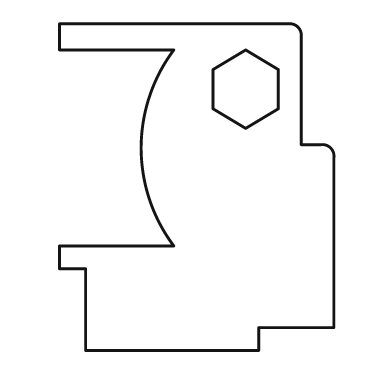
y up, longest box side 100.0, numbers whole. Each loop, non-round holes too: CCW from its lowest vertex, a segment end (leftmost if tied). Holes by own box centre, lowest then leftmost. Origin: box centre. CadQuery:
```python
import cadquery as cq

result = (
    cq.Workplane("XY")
    .moveTo(-34.0, -50.0)
    .lineTo(19.0, -50.0)
    .lineTo(19.0, -43.0)
    .lineTo(42.0, -43.0)
    .lineTo(42.0, 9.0)
    .threePointArc((41.0, 12.0), (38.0, 13.0))
    .lineTo(32.0, 13.0)
    .lineTo(32.0, 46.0)
    .threePointArc((31.0, 49.0), (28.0, 50.0))
    .lineTo(-42.0, 50.0)
    .lineTo(-42.0, 42.0)
    .lineTo(-7.0, 42.0)
    .threePointArc((-17.0, 12.0), (-7.0, -18.0))
    .lineTo(-42.0, -18.0)
    .lineTo(-42.0, -25.0)
    .lineTo(-34.0, -25.0)
    .close()
    .moveTo(15.0, 18.0)
    .lineTo(25.0, 24.0)
    .lineTo(25.0, 36.0)
    .lineTo(15.0, 42.0)
    .lineTo(5.0, 36.0)
    .lineTo(5.0, 24.0)
    .close()
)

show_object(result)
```